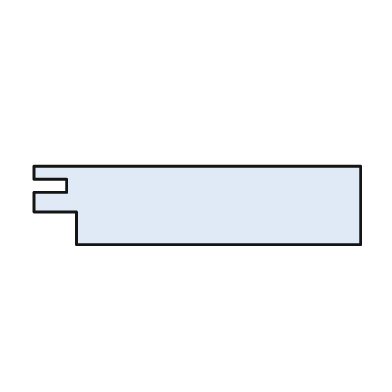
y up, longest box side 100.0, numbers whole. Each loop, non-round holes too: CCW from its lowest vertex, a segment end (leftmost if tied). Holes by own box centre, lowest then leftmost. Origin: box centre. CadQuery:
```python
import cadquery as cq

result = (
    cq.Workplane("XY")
    .moveTo(-37.0, -12.0)
    .lineTo(50.0, -12.0)
    .lineTo(50.0, 12.0)
    .lineTo(-50.0, 12.0)
    .lineTo(-50.0, 8.0)
    .lineTo(-40.0, 8.0)
    .lineTo(-40.0, 4.0)
    .lineTo(-50.0, 4.0)
    .lineTo(-50.0, -2.0)
    .lineTo(-37.0, -2.0)
    .close()
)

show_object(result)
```